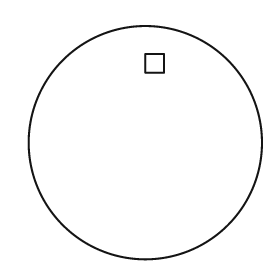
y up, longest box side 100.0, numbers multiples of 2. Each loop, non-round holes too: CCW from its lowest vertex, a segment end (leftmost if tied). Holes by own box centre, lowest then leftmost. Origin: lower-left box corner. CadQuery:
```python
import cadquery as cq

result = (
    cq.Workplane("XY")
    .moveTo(50.0, 50.0)
    .circle(50.0)
    .moveTo(50.0, 80.0)
    .lineTo(58.0, 80.0)
    .lineTo(58.0, 88.0)
    .lineTo(50.0, 88.0)
    .close()
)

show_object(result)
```